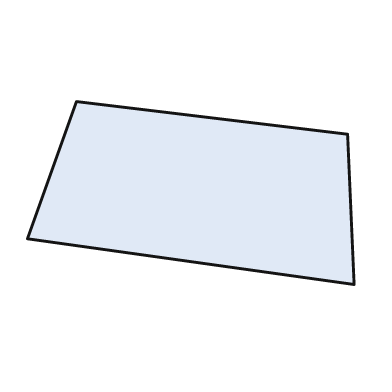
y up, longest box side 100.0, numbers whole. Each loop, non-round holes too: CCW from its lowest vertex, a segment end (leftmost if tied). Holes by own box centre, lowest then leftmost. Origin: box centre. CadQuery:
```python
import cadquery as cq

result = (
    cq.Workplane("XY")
    .moveTo(50.0, -28.0)
    .lineTo(48.0, 18.0)
    .lineTo(-35.0, 28.0)
    .lineTo(-50.0, -14.0)
    .close()
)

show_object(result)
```